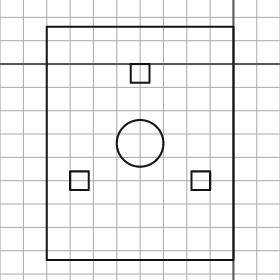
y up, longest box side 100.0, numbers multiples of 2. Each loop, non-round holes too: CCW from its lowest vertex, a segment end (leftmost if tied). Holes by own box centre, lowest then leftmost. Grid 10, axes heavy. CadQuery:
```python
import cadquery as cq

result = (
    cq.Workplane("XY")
    .moveTo(-80.0, -84.0)
    .lineTo(0.0, -84.0)
    .lineTo(0.0, 16.0)
    .lineTo(-80.0, 16.0)
    .close()
    .moveTo(-70.0, -54.0)
    .lineTo(-62.0, -54.0)
    .lineTo(-62.0, -46.0)
    .lineTo(-70.0, -46.0)
    .close()
    .moveTo(-18.0, -54.0)
    .lineTo(-10.0, -54.0)
    .lineTo(-10.0, -46.0)
    .lineTo(-18.0, -46.0)
    .close()
    .moveTo(-40.0, -34.0)
    .circle(10.0)
    .moveTo(-44.0, -8.0)
    .lineTo(-36.0, -8.0)
    .lineTo(-36.0, 0.0)
    .lineTo(-44.0, 0.0)
    .close()
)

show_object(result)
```